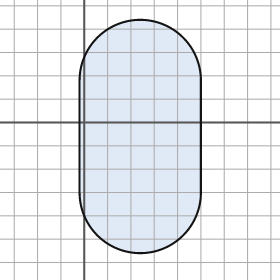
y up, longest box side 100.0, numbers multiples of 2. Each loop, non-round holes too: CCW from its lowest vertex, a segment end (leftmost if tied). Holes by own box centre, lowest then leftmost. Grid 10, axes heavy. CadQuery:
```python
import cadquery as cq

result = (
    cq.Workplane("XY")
    .moveTo(-2.0, -30.0)
    .threePointArc((24.0, -56.0), (50.0, -30.0))
    .lineTo(50.0, 18.0)
    .threePointArc((24.0, 44.0), (-2.0, 18.0))
    .close()
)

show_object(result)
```